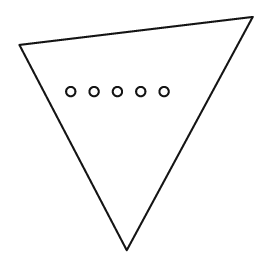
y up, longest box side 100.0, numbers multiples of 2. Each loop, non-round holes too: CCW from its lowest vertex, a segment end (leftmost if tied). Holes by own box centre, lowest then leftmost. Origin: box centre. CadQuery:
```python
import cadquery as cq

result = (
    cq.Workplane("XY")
    .moveTo(-4.0, -50.0)
    .lineTo(50.0, 50.0)
    .lineTo(-50.0, 38.0)
    .close()
    .moveTo(-28.0, 18.0)
    .circle(2.0)
    .moveTo(-18.0, 18.0)
    .circle(2.0)
    .moveTo(-8.0, 18.0)
    .circle(2.0)
    .moveTo(2.0, 18.0)
    .circle(2.0)
    .moveTo(12.0, 18.0)
    .circle(2.0)
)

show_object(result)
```